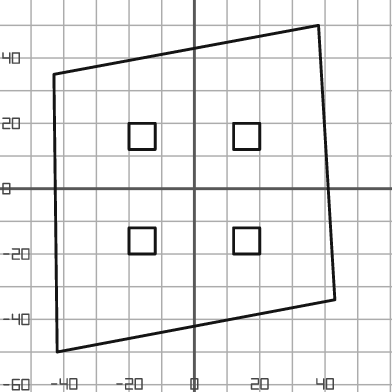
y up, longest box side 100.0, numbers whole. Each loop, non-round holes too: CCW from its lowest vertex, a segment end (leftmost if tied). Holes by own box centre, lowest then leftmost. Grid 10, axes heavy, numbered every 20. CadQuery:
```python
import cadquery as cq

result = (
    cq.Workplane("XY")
    .moveTo(-42.0, -50.0)
    .lineTo(43.0, -34.0)
    .lineTo(38.0, 50.0)
    .lineTo(-43.0, 35.0)
    .close()
    .moveTo(-20.0, -20.0)
    .lineTo(-12.0, -20.0)
    .lineTo(-12.0, -12.0)
    .lineTo(-20.0, -12.0)
    .close()
    .moveTo(12.0, -20.0)
    .lineTo(20.0, -20.0)
    .lineTo(20.0, -12.0)
    .lineTo(12.0, -12.0)
    .close()
    .moveTo(-20.0, 12.0)
    .lineTo(-12.0, 12.0)
    .lineTo(-12.0, 20.0)
    .lineTo(-20.0, 20.0)
    .close()
    .moveTo(12.0, 12.0)
    .lineTo(20.0, 12.0)
    .lineTo(20.0, 20.0)
    .lineTo(12.0, 20.0)
    .close()
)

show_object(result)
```